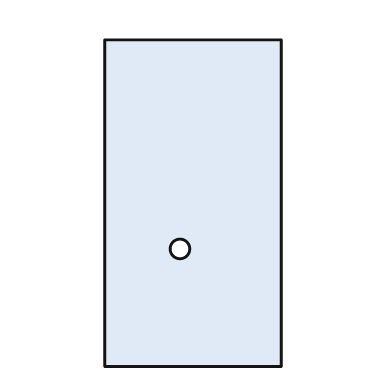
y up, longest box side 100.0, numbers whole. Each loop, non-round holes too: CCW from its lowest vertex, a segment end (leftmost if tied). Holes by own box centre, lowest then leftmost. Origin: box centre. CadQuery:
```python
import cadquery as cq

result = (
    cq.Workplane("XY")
    .moveTo(-27.0, -50.0)
    .lineTo(27.0, -50.0)
    .lineTo(27.0, 50.0)
    .lineTo(-27.0, 50.0)
    .close()
    .moveTo(-4.0, -14.0)
    .circle(3.0)
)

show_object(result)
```